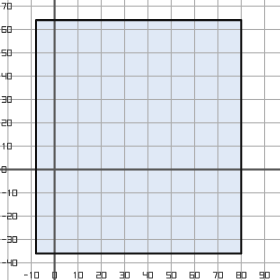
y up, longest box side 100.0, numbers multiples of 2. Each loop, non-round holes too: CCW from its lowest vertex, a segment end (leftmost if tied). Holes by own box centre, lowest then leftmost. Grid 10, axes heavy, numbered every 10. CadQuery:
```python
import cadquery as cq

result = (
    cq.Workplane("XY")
    .moveTo(-8.0, -36.0)
    .lineTo(80.0, -36.0)
    .lineTo(80.0, 64.0)
    .lineTo(-8.0, 64.0)
    .close()
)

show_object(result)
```